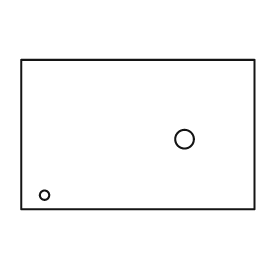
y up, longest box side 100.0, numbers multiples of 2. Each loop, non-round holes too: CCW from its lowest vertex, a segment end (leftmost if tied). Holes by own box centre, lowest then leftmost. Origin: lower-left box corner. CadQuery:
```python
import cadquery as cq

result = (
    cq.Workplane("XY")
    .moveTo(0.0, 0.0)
    .lineTo(100.0, 0.0)
    .lineTo(100.0, 64.0)
    .lineTo(0.0, 64.0)
    .close()
    .moveTo(10.0, 6.0)
    .circle(2.0)
    .moveTo(70.0, 30.0)
    .circle(4.0)
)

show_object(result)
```